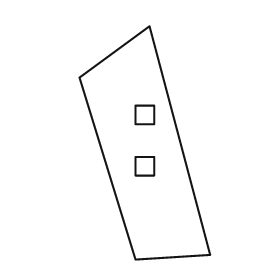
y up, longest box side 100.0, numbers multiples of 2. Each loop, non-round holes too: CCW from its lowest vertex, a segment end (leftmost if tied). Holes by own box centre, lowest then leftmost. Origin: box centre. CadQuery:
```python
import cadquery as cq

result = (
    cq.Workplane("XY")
    .moveTo(-4.0, -50.0)
    .lineTo(28.0, -48.0)
    .lineTo(2.0, 50.0)
    .lineTo(-28.0, 28.0)
    .close()
    .moveTo(-4.0, -14.0)
    .lineTo(4.0, -14.0)
    .lineTo(4.0, -6.0)
    .lineTo(-4.0, -6.0)
    .close()
    .moveTo(-4.0, 8.0)
    .lineTo(4.0, 8.0)
    .lineTo(4.0, 16.0)
    .lineTo(-4.0, 16.0)
    .close()
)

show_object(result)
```